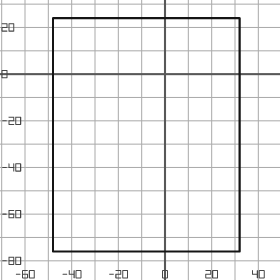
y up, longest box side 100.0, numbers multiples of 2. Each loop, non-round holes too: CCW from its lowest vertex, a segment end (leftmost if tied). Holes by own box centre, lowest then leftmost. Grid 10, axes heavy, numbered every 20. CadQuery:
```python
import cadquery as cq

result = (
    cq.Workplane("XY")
    .moveTo(-48.0, -76.0)
    .lineTo(32.0, -76.0)
    .lineTo(32.0, 24.0)
    .lineTo(-48.0, 24.0)
    .close()
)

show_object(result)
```